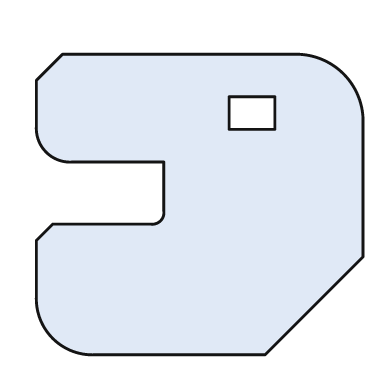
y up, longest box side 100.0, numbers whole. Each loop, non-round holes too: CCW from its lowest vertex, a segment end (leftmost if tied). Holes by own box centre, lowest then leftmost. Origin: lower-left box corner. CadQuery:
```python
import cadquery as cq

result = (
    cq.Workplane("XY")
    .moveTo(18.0, 0.0)
    .lineTo(70.0, 0.0)
    .lineTo(100.0, 30.0)
    .lineTo(100.0, 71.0)
    .threePointArc((94.0, 86.0), (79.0, 92.0))
    .lineTo(8.0, 92.0)
    .lineTo(0.0, 84.0)
    .lineTo(0.0, 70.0)
    .threePointArc((3.0, 62.0), (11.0, 59.0))
    .lineTo(39.0, 59.0)
    .lineTo(39.0, 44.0)
    .threePointArc((38.0, 41.0), (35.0, 40.0))
    .lineTo(5.0, 40.0)
    .lineTo(0.0, 35.0)
    .lineTo(0.0, 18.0)
    .threePointArc((5.0, 5.0), (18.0, 0.0))
    .close()
    .moveTo(59.0, 69.0)
    .lineTo(73.0, 69.0)
    .lineTo(73.0, 79.0)
    .lineTo(59.0, 79.0)
    .close()
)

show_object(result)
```